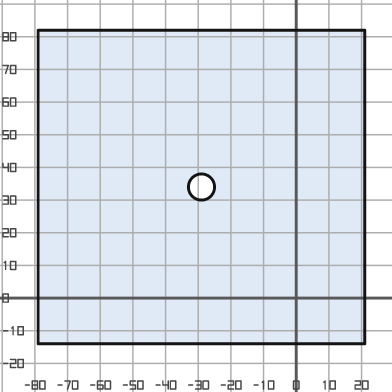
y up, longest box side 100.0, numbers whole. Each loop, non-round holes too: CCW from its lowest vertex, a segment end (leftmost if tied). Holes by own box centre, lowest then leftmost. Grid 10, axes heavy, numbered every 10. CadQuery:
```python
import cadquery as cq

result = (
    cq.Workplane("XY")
    .moveTo(-79.0, -14.0)
    .lineTo(21.0, -14.0)
    .lineTo(21.0, 82.0)
    .lineTo(-79.0, 82.0)
    .close()
    .moveTo(-29.0, 34.0)
    .circle(4.0)
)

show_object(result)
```